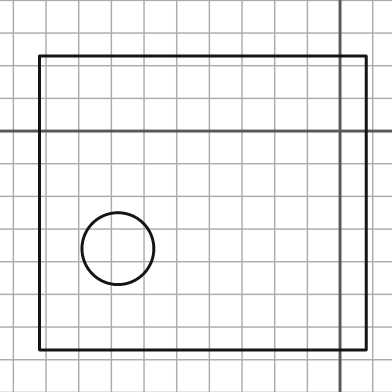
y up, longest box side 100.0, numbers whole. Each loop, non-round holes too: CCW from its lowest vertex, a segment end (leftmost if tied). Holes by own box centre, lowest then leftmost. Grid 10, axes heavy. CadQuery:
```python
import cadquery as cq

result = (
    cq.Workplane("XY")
    .moveTo(-92.0, -67.0)
    .lineTo(8.0, -67.0)
    .lineTo(8.0, 23.0)
    .lineTo(-92.0, 23.0)
    .close()
    .moveTo(-68.0, -36.0)
    .circle(11.0)
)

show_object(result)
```